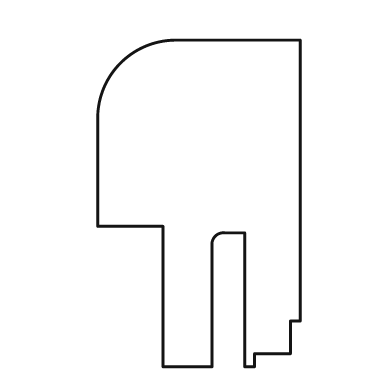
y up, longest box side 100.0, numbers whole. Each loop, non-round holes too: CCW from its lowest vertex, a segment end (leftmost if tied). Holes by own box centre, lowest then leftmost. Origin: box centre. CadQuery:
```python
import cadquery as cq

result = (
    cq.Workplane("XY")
    .moveTo(-11.0, -50.0)
    .lineTo(4.0, -50.0)
    .lineTo(4.0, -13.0)
    .threePointArc((5.0, -10.0), (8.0, -9.0))
    .lineTo(14.0, -9.0)
    .lineTo(14.0, -50.0)
    .lineTo(17.0, -50.0)
    .lineTo(17.0, -46.0)
    .lineTo(28.0, -46.0)
    .lineTo(28.0, -36.0)
    .lineTo(31.0, -36.0)
    .lineTo(31.0, 50.0)
    .lineTo(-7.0, 50.0)
    .threePointArc((-24.0, 43.0), (-31.0, 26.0))
    .lineTo(-31.0, -7.0)
    .lineTo(-11.0, -7.0)
    .close()
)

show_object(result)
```